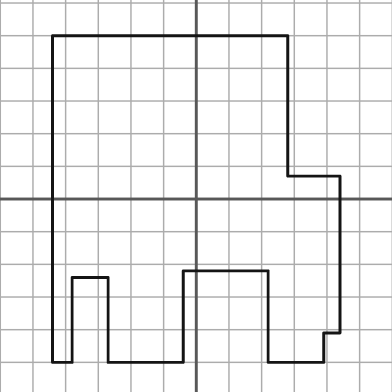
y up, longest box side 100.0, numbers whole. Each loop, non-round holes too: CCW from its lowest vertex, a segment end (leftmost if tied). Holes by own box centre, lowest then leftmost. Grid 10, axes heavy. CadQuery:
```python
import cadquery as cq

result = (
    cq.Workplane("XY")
    .moveTo(-44.0, -50.0)
    .lineTo(-38.0, -50.0)
    .lineTo(-38.0, -24.0)
    .lineTo(-27.0, -24.0)
    .lineTo(-27.0, -50.0)
    .lineTo(-4.0, -50.0)
    .lineTo(-4.0, -22.0)
    .lineTo(22.0, -22.0)
    .lineTo(22.0, -50.0)
    .lineTo(39.0, -50.0)
    .lineTo(39.0, -41.0)
    .lineTo(44.0, -41.0)
    .lineTo(44.0, 7.0)
    .lineTo(28.0, 7.0)
    .lineTo(28.0, 50.0)
    .lineTo(-44.0, 50.0)
    .close()
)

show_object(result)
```